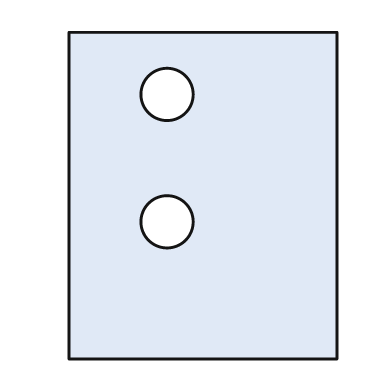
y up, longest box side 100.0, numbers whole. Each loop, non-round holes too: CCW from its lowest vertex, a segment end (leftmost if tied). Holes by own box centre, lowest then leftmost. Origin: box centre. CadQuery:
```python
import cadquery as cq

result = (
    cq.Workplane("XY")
    .moveTo(-41.0, -50.0)
    .lineTo(41.0, -50.0)
    .lineTo(41.0, 50.0)
    .lineTo(-41.0, 50.0)
    .close()
    .moveTo(-11.0, -8.0)
    .circle(8.0)
    .moveTo(-11.0, 31.0)
    .circle(8.0)
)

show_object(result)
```